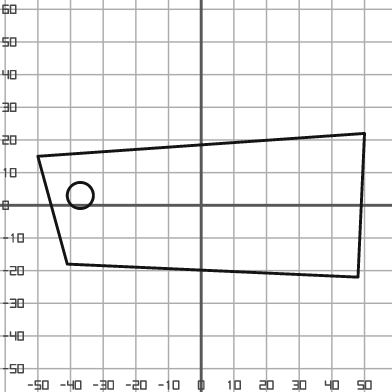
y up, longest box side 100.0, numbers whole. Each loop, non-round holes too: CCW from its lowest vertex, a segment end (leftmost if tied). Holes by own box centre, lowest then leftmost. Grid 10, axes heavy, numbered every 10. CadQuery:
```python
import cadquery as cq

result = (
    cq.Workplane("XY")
    .moveTo(48.0, -22.0)
    .lineTo(50.0, 22.0)
    .lineTo(-50.0, 15.0)
    .lineTo(-41.0, -18.0)
    .close()
    .moveTo(-37.0, 3.0)
    .circle(4.0)
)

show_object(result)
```